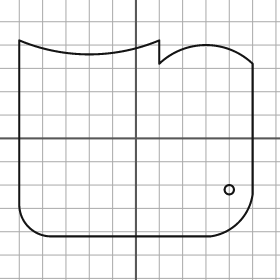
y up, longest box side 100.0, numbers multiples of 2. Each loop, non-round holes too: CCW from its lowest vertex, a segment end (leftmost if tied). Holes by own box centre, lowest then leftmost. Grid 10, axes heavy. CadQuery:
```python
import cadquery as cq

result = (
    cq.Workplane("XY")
    .moveTo(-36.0, -42.0)
    .lineTo(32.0, -42.0)
    .threePointArc((44.0, -36.0), (50.0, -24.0))
    .lineTo(50.0, 32.0)
    .threePointArc((30.0, 40.0), (10.0, 32.0))
    .lineTo(10.0, 42.0)
    .threePointArc((-20.0, 36.0), (-50.0, 42.0))
    .lineTo(-50.0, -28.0)
    .threePointArc((-46.0, -38.0), (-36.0, -42.0))
    .close()
    .moveTo(40.0, -22.0)
    .circle(2.0)
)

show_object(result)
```